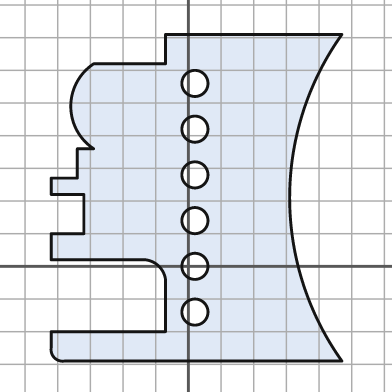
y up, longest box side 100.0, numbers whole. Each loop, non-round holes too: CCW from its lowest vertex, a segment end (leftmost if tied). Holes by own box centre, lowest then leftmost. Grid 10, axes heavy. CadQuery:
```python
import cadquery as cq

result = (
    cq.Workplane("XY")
    .moveTo(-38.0, -29.0)
    .lineTo(47.0, -29.0)
    .threePointArc((31.0, 21.0), (47.0, 71.0))
    .lineTo(-7.0, 71.0)
    .lineTo(-7.0, 62.0)
    .lineTo(-29.0, 62.0)
    .threePointArc((-36.0, 49.0), (-29.0, 36.0))
    .lineTo(-34.0, 36.0)
    .lineTo(-34.0, 27.0)
    .lineTo(-42.0, 27.0)
    .lineTo(-42.0, 22.0)
    .lineTo(-32.0, 22.0)
    .lineTo(-32.0, 10.0)
    .lineTo(-42.0, 10.0)
    .lineTo(-42.0, 2.0)
    .lineTo(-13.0, 2.0)
    .threePointArc((-9.0, 0.0), (-7.0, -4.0))
    .lineTo(-7.0, -20.0)
    .lineTo(-42.0, -20.0)
    .lineTo(-42.0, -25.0)
    .threePointArc((-41.0, -28.0), (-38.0, -29.0))
    .close()
    .moveTo(2.0, -14.0)
    .circle(4.0)
    .moveTo(2.0, 0.0)
    .circle(4.0)
    .moveTo(2.0, 14.0)
    .circle(4.0)
    .moveTo(2.0, 28.0)
    .circle(4.0)
    .moveTo(2.0, 42.0)
    .circle(4.0)
    .moveTo(2.0, 56.0)
    .circle(4.0)
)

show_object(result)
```